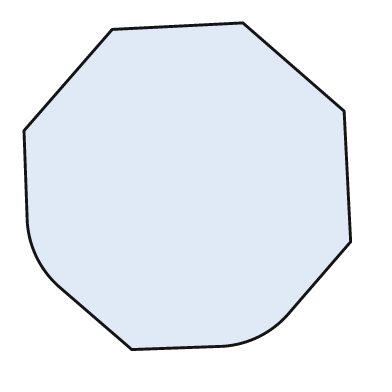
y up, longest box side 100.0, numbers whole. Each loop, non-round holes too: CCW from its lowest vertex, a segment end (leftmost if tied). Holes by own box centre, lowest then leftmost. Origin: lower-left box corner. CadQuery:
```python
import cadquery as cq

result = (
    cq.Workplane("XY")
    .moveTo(33.0, 0.0)
    .lineTo(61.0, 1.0)
    .threePointArc((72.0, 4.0), (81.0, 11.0))
    .lineTo(100.0, 33.0)
    .lineTo(98.0, 73.0)
    .lineTo(67.0, 100.0)
    .lineTo(27.0, 98.0)
    .lineTo(0.0, 67.0)
    .lineTo(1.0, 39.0)
    .threePointArc((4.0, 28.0), (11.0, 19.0))
    .close()
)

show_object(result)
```